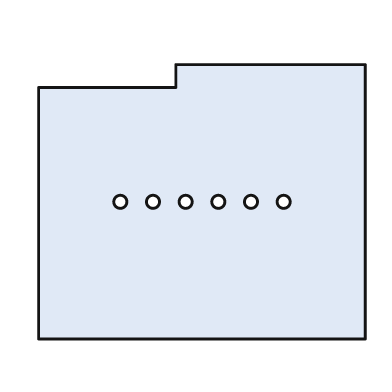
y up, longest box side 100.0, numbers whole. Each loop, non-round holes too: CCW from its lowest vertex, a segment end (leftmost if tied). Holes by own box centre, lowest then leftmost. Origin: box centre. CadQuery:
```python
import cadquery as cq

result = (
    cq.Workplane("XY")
    .moveTo(-50.0, -42.0)
    .lineTo(50.0, -42.0)
    .lineTo(50.0, 42.0)
    .lineTo(-8.0, 42.0)
    .lineTo(-8.0, 35.0)
    .lineTo(-50.0, 35.0)
    .close()
    .moveTo(-25.0, 0.0)
    .circle(2.0)
    .moveTo(-15.0, 0.0)
    .circle(2.0)
    .moveTo(-5.0, 0.0)
    .circle(2.0)
    .moveTo(5.0, 0.0)
    .circle(2.0)
    .moveTo(15.0, 0.0)
    .circle(2.0)
    .moveTo(25.0, 0.0)
    .circle(2.0)
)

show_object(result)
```